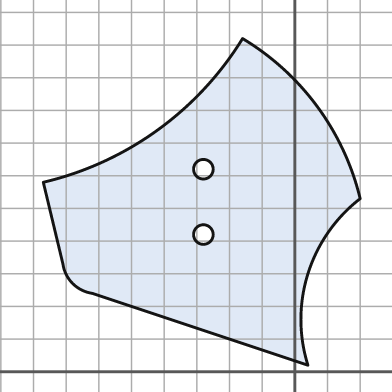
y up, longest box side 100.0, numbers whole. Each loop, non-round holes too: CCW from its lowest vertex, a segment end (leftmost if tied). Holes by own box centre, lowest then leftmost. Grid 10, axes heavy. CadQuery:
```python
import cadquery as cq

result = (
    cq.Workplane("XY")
    .moveTo(4.0, 2.0)
    .threePointArc((4.0, 30.0), (20.0, 53.0))
    .threePointArc((7.0, 81.0), (-16.0, 102.0))
    .threePointArc((-42.0, 74.0), (-77.0, 58.0))
    .lineTo(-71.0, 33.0)
    .threePointArc((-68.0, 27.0), (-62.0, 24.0))
    .close()
    .moveTo(-28.0, 42.0)
    .circle(3.0)
    .moveTo(-28.0, 62.0)
    .circle(3.0)
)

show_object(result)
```